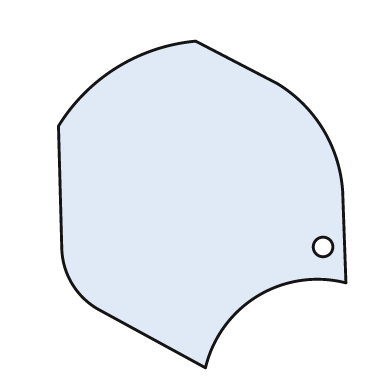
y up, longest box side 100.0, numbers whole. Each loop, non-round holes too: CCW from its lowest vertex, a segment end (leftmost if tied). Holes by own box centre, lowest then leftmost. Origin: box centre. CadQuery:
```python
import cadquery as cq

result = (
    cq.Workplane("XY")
    .moveTo(1.0, -50.0)
    .threePointArc((17.0, -28.0), (44.0, -24.0))
    .lineTo(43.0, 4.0)
    .threePointArc((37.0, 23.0), (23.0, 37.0))
    .lineTo(-2.0, 50.0)
    .threePointArc((-26.0, 42.0), (-44.0, 24.0))
    .lineTo(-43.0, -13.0)
    .threePointArc((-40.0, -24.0), (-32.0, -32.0))
    .close()
    .moveTo(37.0, -13.0)
    .circle(3.0)
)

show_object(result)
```